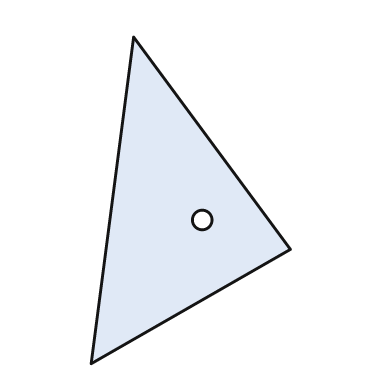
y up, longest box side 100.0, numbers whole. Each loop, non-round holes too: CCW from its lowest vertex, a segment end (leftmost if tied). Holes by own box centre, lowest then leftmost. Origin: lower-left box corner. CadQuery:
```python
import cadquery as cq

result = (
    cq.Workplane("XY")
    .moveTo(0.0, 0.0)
    .lineTo(61.0, 35.0)
    .lineTo(13.0, 100.0)
    .close()
    .moveTo(34.0, 44.0)
    .circle(3.0)
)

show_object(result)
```